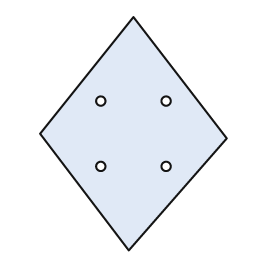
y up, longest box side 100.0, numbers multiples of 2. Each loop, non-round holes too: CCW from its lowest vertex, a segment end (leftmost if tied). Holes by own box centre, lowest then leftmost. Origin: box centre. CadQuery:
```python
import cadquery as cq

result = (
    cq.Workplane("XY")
    .moveTo(-2.0, -50.0)
    .lineTo(40.0, -2.0)
    .lineTo(0.0, 50.0)
    .lineTo(-40.0, 0.0)
    .close()
    .moveTo(-14.0, -14.0)
    .circle(2.0)
    .moveTo(14.0, -14.0)
    .circle(2.0)
    .moveTo(-14.0, 14.0)
    .circle(2.0)
    .moveTo(14.0, 14.0)
    .circle(2.0)
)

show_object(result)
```